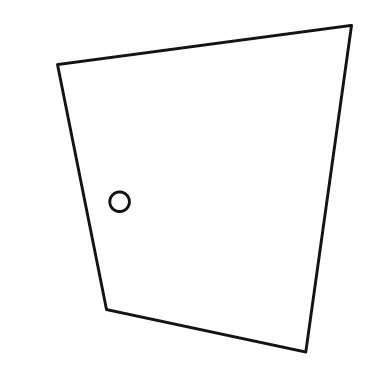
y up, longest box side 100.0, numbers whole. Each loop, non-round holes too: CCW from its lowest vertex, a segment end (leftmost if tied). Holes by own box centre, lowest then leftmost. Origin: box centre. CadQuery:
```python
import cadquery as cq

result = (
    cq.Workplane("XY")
    .moveTo(31.0, -50.0)
    .lineTo(45.0, 50.0)
    .lineTo(-45.0, 38.0)
    .lineTo(-30.0, -37.0)
    .close()
    .moveTo(-26.0, -4.0)
    .circle(3.0)
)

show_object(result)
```